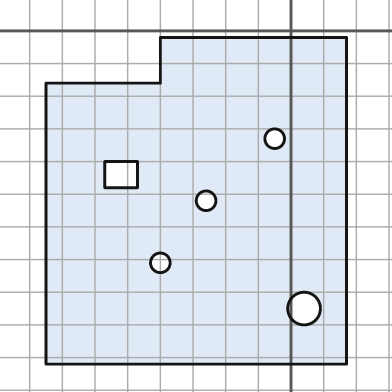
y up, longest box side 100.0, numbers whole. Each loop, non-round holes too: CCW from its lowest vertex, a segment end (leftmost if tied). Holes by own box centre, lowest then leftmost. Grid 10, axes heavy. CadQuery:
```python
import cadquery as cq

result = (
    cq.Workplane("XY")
    .moveTo(-75.0, -102.0)
    .lineTo(17.0, -102.0)
    .lineTo(17.0, -2.0)
    .lineTo(-40.0, -2.0)
    .lineTo(-40.0, -16.0)
    .lineTo(-75.0, -16.0)
    .close()
    .moveTo(4.0, -85.0)
    .circle(5.0)
    .moveTo(-40.0, -71.0)
    .circle(3.0)
    .moveTo(-26.0, -52.0)
    .circle(3.0)
    .moveTo(-57.0, -48.0)
    .lineTo(-47.0, -48.0)
    .lineTo(-47.0, -40.0)
    .lineTo(-57.0, -40.0)
    .close()
    .moveTo(-5.0, -33.0)
    .circle(3.0)
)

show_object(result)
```